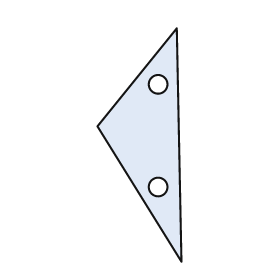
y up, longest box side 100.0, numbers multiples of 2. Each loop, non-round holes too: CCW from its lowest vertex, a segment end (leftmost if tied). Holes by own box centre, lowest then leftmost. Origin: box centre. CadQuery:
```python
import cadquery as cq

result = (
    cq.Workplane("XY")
    .moveTo(18.0, -50.0)
    .lineTo(16.0, 50.0)
    .lineTo(-18.0, 8.0)
    .close()
    .moveTo(8.0, -18.0)
    .circle(4.0)
    .moveTo(8.0, 26.0)
    .circle(4.0)
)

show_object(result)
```